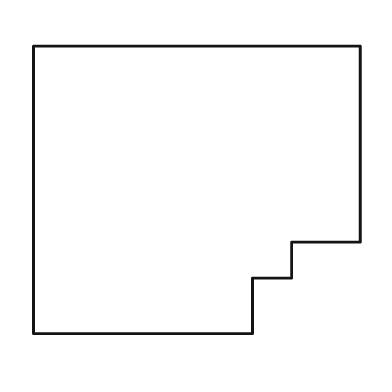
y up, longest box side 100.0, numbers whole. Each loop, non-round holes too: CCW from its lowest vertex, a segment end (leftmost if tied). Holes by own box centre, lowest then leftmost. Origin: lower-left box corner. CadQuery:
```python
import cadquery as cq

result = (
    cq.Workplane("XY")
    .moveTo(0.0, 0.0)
    .lineTo(67.0, 0.0)
    .lineTo(67.0, 17.0)
    .lineTo(79.0, 17.0)
    .lineTo(79.0, 28.0)
    .lineTo(100.0, 28.0)
    .lineTo(100.0, 88.0)
    .lineTo(0.0, 88.0)
    .close()
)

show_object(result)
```